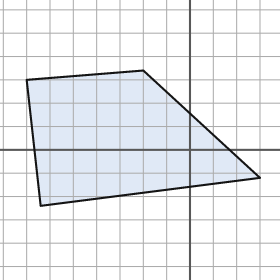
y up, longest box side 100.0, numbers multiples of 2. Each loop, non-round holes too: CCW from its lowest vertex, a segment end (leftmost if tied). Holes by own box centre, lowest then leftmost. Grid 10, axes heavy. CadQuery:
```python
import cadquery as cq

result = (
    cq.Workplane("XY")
    .moveTo(-64.0, -24.0)
    .lineTo(30.0, -12.0)
    .lineTo(-20.0, 34.0)
    .lineTo(-70.0, 30.0)
    .close()
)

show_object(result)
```